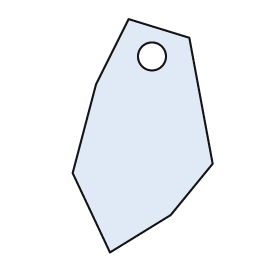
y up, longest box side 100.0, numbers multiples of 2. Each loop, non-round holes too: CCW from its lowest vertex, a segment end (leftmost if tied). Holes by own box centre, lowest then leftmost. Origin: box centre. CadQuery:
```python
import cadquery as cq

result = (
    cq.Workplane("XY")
    .moveTo(-14.0, -50.0)
    .lineTo(12.0, -34.0)
    .lineTo(30.0, -12.0)
    .lineTo(20.0, 42.0)
    .lineTo(-6.0, 50.0)
    .lineTo(-20.0, 22.0)
    .lineTo(-30.0, -16.0)
    .close()
    .moveTo(4.0, 34.0)
    .circle(6.0)
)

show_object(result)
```